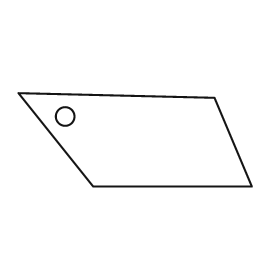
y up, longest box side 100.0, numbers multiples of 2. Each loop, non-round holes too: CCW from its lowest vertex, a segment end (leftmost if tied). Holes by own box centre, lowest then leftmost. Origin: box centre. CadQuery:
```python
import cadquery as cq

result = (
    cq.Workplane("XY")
    .moveTo(-18.0, -20.0)
    .lineTo(50.0, -20.0)
    .lineTo(34.0, 18.0)
    .lineTo(-50.0, 20.0)
    .close()
    .moveTo(-30.0, 10.0)
    .circle(4.0)
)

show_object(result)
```